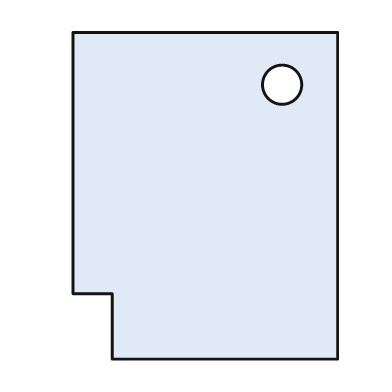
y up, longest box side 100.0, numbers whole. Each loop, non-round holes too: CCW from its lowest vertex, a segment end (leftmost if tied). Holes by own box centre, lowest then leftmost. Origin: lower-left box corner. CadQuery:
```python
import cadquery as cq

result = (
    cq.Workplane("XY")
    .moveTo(12.0, 0.0)
    .lineTo(81.0, 0.0)
    .lineTo(81.0, 100.0)
    .lineTo(0.0, 100.0)
    .lineTo(0.0, 20.0)
    .lineTo(12.0, 20.0)
    .close()
    .moveTo(64.0, 84.0)
    .circle(6.0)
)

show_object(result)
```